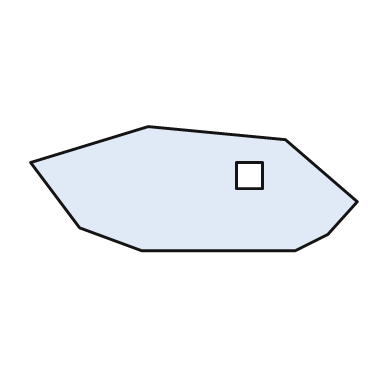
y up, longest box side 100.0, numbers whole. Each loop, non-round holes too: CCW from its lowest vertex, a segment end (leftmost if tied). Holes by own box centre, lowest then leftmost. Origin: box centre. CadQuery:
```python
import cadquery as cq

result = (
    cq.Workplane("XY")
    .moveTo(-16.0, -19.0)
    .lineTo(31.0, -19.0)
    .lineTo(41.0, -14.0)
    .lineTo(50.0, -4.0)
    .lineTo(28.0, 15.0)
    .lineTo(-14.0, 19.0)
    .lineTo(-50.0, 8.0)
    .lineTo(-35.0, -12.0)
    .close()
    .moveTo(13.0, 0.0)
    .lineTo(21.0, 0.0)
    .lineTo(21.0, 8.0)
    .lineTo(13.0, 8.0)
    .close()
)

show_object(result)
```